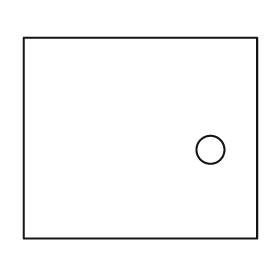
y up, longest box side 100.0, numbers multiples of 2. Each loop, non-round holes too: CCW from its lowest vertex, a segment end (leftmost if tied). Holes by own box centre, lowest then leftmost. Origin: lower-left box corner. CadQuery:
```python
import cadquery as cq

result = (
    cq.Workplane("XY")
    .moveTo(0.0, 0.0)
    .lineTo(100.0, 0.0)
    .lineTo(100.0, 86.0)
    .lineTo(0.0, 86.0)
    .close()
    .moveTo(80.0, 38.0)
    .circle(6.0)
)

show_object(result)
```